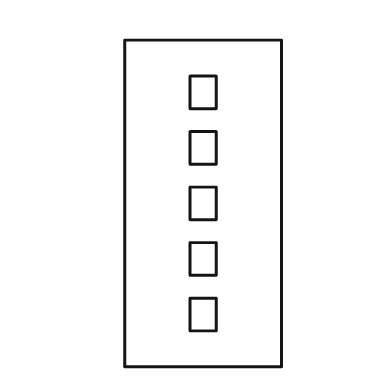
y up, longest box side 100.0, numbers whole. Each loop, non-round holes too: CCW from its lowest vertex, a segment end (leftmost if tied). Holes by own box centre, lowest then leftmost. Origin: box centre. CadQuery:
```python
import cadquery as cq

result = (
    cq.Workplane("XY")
    .moveTo(-24.0, -50.0)
    .lineTo(24.0, -50.0)
    .lineTo(24.0, 50.0)
    .lineTo(-24.0, 50.0)
    .close()
    .moveTo(-4.0, -39.0)
    .lineTo(4.0, -39.0)
    .lineTo(4.0, -29.0)
    .lineTo(-4.0, -29.0)
    .close()
    .moveTo(-4.0, -22.0)
    .lineTo(4.0, -22.0)
    .lineTo(4.0, -12.0)
    .lineTo(-4.0, -12.0)
    .close()
    .moveTo(-4.0, -5.0)
    .lineTo(4.0, -5.0)
    .lineTo(4.0, 5.0)
    .lineTo(-4.0, 5.0)
    .close()
    .moveTo(-4.0, 12.0)
    .lineTo(4.0, 12.0)
    .lineTo(4.0, 22.0)
    .lineTo(-4.0, 22.0)
    .close()
    .moveTo(-4.0, 29.0)
    .lineTo(4.0, 29.0)
    .lineTo(4.0, 39.0)
    .lineTo(-4.0, 39.0)
    .close()
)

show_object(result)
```